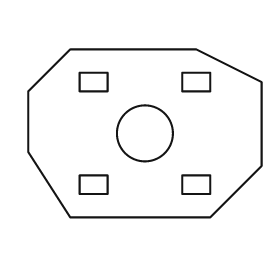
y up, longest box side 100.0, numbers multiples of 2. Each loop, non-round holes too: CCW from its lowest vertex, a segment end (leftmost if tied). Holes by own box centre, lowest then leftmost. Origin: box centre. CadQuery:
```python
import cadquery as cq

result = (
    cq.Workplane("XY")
    .moveTo(-32.0, -36.0)
    .lineTo(28.0, -36.0)
    .lineTo(50.0, -14.0)
    .lineTo(50.0, 22.0)
    .lineTo(22.0, 36.0)
    .lineTo(-32.0, 36.0)
    .lineTo(-50.0, 18.0)
    .lineTo(-50.0, -8.0)
    .close()
    .moveTo(-28.0, -26.0)
    .lineTo(-16.0, -26.0)
    .lineTo(-16.0, -18.0)
    .lineTo(-28.0, -18.0)
    .close()
    .moveTo(16.0, -26.0)
    .lineTo(28.0, -26.0)
    .lineTo(28.0, -18.0)
    .lineTo(16.0, -18.0)
    .close()
    .moveTo(0.0, 0.0)
    .circle(12.0)
    .moveTo(-28.0, 18.0)
    .lineTo(-16.0, 18.0)
    .lineTo(-16.0, 26.0)
    .lineTo(-28.0, 26.0)
    .close()
    .moveTo(16.0, 18.0)
    .lineTo(28.0, 18.0)
    .lineTo(28.0, 26.0)
    .lineTo(16.0, 26.0)
    .close()
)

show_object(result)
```